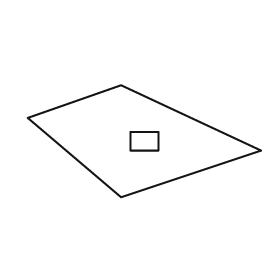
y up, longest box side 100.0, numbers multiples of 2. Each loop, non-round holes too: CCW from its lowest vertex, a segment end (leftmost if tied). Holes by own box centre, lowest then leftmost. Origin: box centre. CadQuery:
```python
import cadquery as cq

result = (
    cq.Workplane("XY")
    .moveTo(-10.0, -24.0)
    .lineTo(50.0, -4.0)
    .lineTo(-10.0, 24.0)
    .lineTo(-50.0, 10.0)
    .close()
    .moveTo(-6.0, -4.0)
    .lineTo(6.0, -4.0)
    .lineTo(6.0, 4.0)
    .lineTo(-6.0, 4.0)
    .close()
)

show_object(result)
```